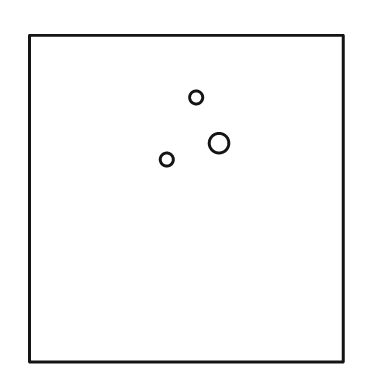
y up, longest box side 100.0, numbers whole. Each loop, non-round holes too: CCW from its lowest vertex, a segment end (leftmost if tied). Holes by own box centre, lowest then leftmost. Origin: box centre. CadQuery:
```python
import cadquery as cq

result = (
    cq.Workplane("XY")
    .moveTo(-48.0, -50.0)
    .lineTo(48.0, -50.0)
    .lineTo(48.0, 50.0)
    .lineTo(-48.0, 50.0)
    .close()
    .moveTo(-6.0, 12.0)
    .circle(2.0)
    .moveTo(10.0, 17.0)
    .circle(3.0)
    .moveTo(3.0, 31.0)
    .circle(2.0)
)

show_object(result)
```